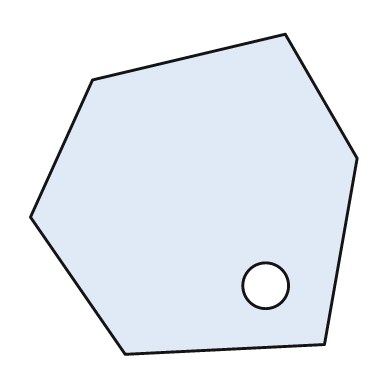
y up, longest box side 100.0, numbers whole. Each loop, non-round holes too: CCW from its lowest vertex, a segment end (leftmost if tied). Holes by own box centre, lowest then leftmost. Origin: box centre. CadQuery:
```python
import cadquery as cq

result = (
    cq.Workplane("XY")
    .moveTo(-21.0, -49.0)
    .lineTo(40.0, -46.0)
    .lineTo(50.0, 11.0)
    .lineTo(28.0, 49.0)
    .lineTo(-31.0, 35.0)
    .lineTo(-50.0, -7.0)
    .close()
    .moveTo(22.0, -28.0)
    .circle(7.0)
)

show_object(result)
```